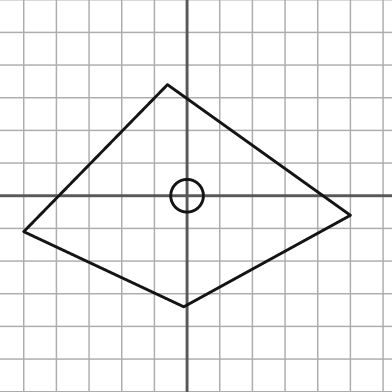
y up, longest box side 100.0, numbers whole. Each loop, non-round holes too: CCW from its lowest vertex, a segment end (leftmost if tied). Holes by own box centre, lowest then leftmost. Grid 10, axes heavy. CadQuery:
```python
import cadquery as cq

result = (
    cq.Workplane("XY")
    .moveTo(-1.0, -34.0)
    .lineTo(50.0, -6.0)
    .lineTo(-6.0, 34.0)
    .lineTo(-50.0, -11.0)
    .close()
    .moveTo(0.0, 0.0)
    .circle(5.0)
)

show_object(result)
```